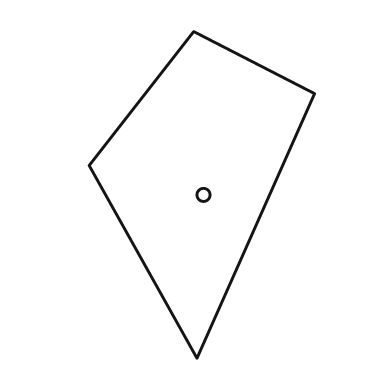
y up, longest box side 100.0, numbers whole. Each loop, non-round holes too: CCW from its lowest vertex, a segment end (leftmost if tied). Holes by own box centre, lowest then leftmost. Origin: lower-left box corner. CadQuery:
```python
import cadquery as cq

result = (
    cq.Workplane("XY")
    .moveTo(33.0, 0.0)
    .lineTo(69.0, 81.0)
    .lineTo(32.0, 100.0)
    .lineTo(0.0, 59.0)
    .close()
    .moveTo(35.0, 50.0)
    .circle(2.0)
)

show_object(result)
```